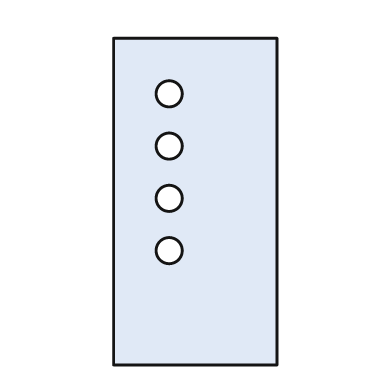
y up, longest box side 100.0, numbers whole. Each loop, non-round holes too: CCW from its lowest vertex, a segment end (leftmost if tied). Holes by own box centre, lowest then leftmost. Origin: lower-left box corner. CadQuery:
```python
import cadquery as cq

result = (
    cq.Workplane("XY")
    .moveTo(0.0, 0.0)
    .lineTo(50.0, 0.0)
    .lineTo(50.0, 100.0)
    .lineTo(0.0, 100.0)
    .close()
    .moveTo(17.0, 35.0)
    .circle(4.0)
    .moveTo(17.0, 51.0)
    .circle(4.0)
    .moveTo(17.0, 67.0)
    .circle(4.0)
    .moveTo(17.0, 83.0)
    .circle(4.0)
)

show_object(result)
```